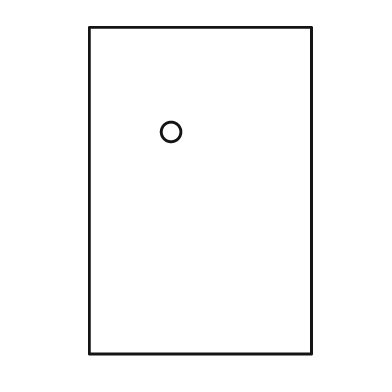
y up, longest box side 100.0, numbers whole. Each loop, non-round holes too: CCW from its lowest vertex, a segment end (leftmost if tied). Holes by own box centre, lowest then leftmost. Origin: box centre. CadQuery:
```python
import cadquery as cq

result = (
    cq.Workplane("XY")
    .moveTo(-34.0, -50.0)
    .lineTo(34.0, -50.0)
    .lineTo(34.0, 50.0)
    .lineTo(-34.0, 50.0)
    .close()
    .moveTo(-9.0, 18.0)
    .circle(3.0)
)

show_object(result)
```